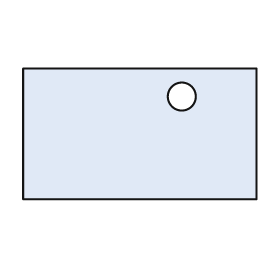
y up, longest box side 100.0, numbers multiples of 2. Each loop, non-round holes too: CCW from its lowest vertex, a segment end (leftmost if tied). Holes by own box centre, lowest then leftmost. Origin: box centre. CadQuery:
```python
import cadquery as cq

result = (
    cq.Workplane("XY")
    .moveTo(-50.0, -28.0)
    .lineTo(50.0, -28.0)
    .lineTo(50.0, 28.0)
    .lineTo(-50.0, 28.0)
    .close()
    .moveTo(18.0, 16.0)
    .circle(6.0)
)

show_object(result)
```